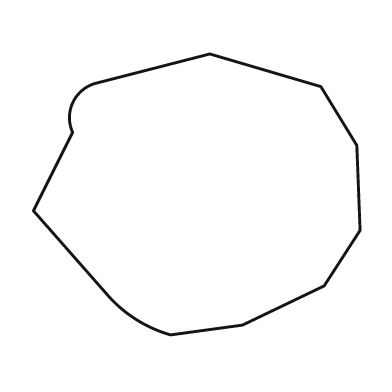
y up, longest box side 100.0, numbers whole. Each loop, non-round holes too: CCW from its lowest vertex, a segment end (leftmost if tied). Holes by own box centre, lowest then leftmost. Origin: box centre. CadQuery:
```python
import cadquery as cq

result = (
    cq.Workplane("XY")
    .moveTo(-8.0, -43.0)
    .lineTo(14.0, -40.0)
    .lineTo(39.0, -28.0)
    .lineTo(50.0, -11.0)
    .lineTo(49.0, 15.0)
    .lineTo(38.0, 33.0)
    .lineTo(4.0, 43.0)
    .lineTo(-31.0, 34.0)
    .threePointArc((-38.0, 28.0), (-38.0, 19.0))
    .lineTo(-50.0, -5.0)
    .lineTo(-28.0, -30.0)
    .threePointArc((-19.0, -38.0), (-8.0, -43.0))
    .close()
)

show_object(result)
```